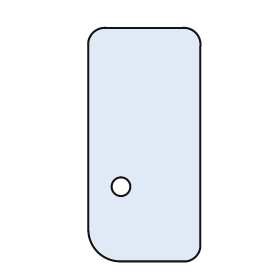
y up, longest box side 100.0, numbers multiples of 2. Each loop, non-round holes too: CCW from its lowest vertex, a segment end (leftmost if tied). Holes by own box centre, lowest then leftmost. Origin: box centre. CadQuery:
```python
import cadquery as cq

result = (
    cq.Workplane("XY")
    .moveTo(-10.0, -50.0)
    .lineTo(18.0, -50.0)
    .threePointArc((22.0, -48.0), (24.0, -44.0))
    .lineTo(24.0, 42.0)
    .threePointArc((22.0, 48.0), (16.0, 50.0))
    .lineTo(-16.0, 50.0)
    .threePointArc((-22.0, 48.0), (-24.0, 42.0))
    .lineTo(-24.0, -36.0)
    .threePointArc((-20.0, -46.0), (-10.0, -50.0))
    .close()
    .moveTo(-10.0, -18.0)
    .circle(4.0)
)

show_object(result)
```